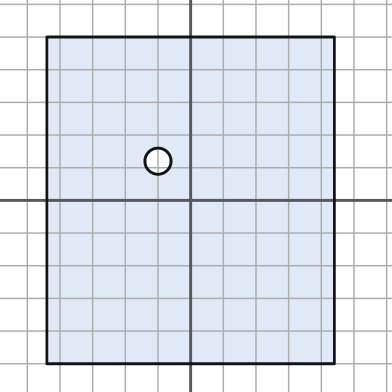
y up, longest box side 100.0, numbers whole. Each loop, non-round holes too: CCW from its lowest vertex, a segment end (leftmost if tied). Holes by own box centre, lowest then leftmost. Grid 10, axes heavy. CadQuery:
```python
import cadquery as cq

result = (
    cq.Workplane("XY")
    .moveTo(-44.0, -50.0)
    .lineTo(44.0, -50.0)
    .lineTo(44.0, 50.0)
    .lineTo(-44.0, 50.0)
    .close()
    .moveTo(-10.0, 12.0)
    .circle(4.0)
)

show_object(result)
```